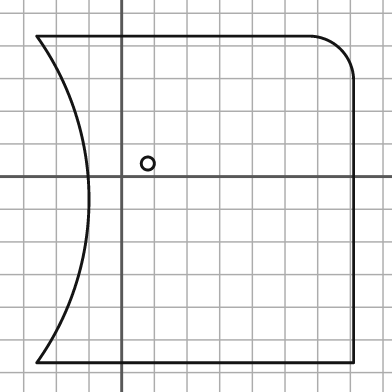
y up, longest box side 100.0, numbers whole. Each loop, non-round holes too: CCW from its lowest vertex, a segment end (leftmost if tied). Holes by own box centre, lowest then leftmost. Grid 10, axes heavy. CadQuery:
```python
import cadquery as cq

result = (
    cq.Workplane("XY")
    .moveTo(-26.0, -57.0)
    .lineTo(71.0, -57.0)
    .lineTo(71.0, 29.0)
    .threePointArc((67.0, 39.0), (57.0, 43.0))
    .lineTo(-26.0, 43.0)
    .threePointArc((-10.0, -7.0), (-26.0, -57.0))
    .close()
    .moveTo(8.0, 4.0)
    .circle(2.0)
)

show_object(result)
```